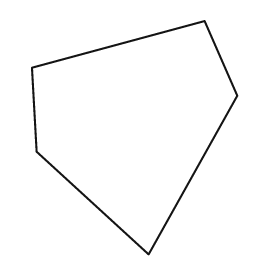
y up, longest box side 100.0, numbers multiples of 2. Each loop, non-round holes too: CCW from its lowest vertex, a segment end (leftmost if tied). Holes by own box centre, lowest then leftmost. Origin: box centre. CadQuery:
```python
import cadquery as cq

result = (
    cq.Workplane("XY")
    .moveTo(6.0, -50.0)
    .lineTo(44.0, 18.0)
    .lineTo(30.0, 50.0)
    .lineTo(-44.0, 30.0)
    .lineTo(-42.0, -6.0)
    .close()
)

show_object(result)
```